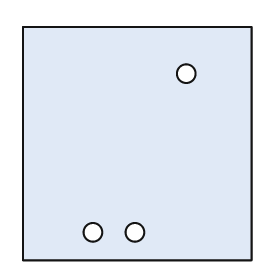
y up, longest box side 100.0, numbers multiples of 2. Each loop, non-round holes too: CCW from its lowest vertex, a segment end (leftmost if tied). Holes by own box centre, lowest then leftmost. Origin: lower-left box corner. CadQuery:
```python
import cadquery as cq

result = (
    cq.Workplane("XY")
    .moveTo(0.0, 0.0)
    .lineTo(98.0, 0.0)
    .lineTo(98.0, 100.0)
    .lineTo(0.0, 100.0)
    .close()
    .moveTo(30.0, 12.0)
    .circle(4.0)
    .moveTo(48.0, 12.0)
    .circle(4.0)
    .moveTo(70.0, 80.0)
    .circle(4.0)
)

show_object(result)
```